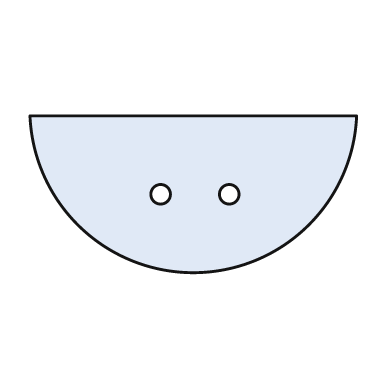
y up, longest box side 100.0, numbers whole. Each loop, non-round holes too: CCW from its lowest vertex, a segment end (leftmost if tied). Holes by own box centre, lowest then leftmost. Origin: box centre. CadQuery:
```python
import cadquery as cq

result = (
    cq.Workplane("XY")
    .moveTo(-50.0, 24.0)
    .threePointArc((0.0, -24.0), (50.0, 24.0))
    .close()
    .moveTo(-10.0, 0.0)
    .circle(3.0)
    .moveTo(11.0, 0.0)
    .circle(3.0)
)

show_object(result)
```